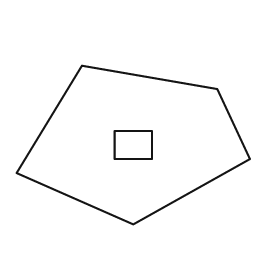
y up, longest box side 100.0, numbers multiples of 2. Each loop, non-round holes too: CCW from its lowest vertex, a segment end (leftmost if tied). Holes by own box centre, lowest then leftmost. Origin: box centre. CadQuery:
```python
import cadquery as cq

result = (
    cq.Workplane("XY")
    .moveTo(0.0, -34.0)
    .lineTo(50.0, -6.0)
    .lineTo(36.0, 24.0)
    .lineTo(-22.0, 34.0)
    .lineTo(-50.0, -12.0)
    .close()
    .moveTo(-8.0, -6.0)
    .lineTo(8.0, -6.0)
    .lineTo(8.0, 6.0)
    .lineTo(-8.0, 6.0)
    .close()
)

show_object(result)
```